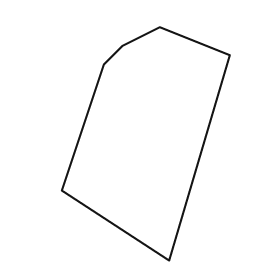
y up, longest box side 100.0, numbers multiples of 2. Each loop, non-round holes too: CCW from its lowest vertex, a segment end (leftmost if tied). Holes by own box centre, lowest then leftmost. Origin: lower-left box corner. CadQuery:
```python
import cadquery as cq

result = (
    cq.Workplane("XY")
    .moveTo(46.0, 0.0)
    .lineTo(72.0, 88.0)
    .lineTo(42.0, 100.0)
    .lineTo(26.0, 92.0)
    .lineTo(18.0, 84.0)
    .lineTo(0.0, 30.0)
    .close()
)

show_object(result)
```